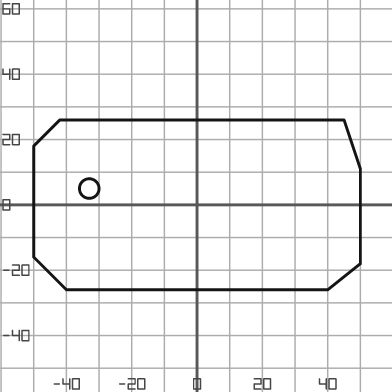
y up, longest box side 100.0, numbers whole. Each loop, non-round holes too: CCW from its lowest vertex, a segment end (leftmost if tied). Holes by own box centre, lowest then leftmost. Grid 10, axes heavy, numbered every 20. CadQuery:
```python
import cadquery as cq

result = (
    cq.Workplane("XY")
    .moveTo(-40.0, -26.0)
    .lineTo(40.0, -26.0)
    .lineTo(50.0, -18.0)
    .lineTo(50.0, 11.0)
    .lineTo(45.0, 26.0)
    .lineTo(-42.0, 26.0)
    .lineTo(-50.0, 18.0)
    .lineTo(-50.0, -16.0)
    .close()
    .moveTo(-33.0, 5.0)
    .circle(3.0)
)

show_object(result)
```